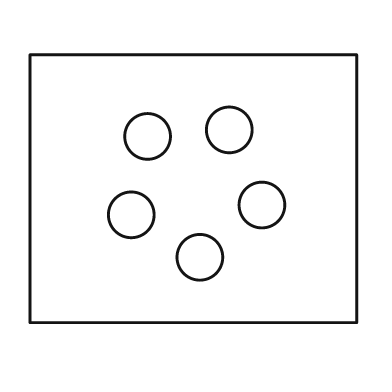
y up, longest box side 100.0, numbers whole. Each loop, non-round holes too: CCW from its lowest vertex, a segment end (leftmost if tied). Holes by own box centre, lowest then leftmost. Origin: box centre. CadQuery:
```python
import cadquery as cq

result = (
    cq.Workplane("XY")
    .moveTo(-50.0, -41.0)
    .lineTo(50.0, -41.0)
    .lineTo(50.0, 41.0)
    .lineTo(-50.0, 41.0)
    .close()
    .moveTo(2.0, -21.0)
    .circle(7.0)
    .moveTo(-19.0, -8.0)
    .circle(7.0)
    .moveTo(21.0, -5.0)
    .circle(7.0)
    .moveTo(-14.0, 16.0)
    .circle(7.0)
    .moveTo(11.0, 18.0)
    .circle(7.0)
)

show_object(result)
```